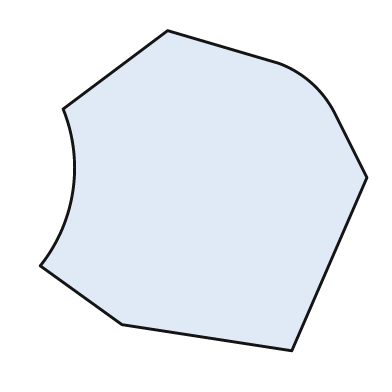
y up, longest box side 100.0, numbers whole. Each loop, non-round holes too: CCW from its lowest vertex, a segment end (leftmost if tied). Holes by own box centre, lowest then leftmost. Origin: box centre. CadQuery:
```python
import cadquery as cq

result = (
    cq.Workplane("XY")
    .moveTo(27.0, -49.0)
    .lineTo(50.0, 4.0)
    .lineTo(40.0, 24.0)
    .threePointArc((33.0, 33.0), (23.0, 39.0))
    .lineTo(-11.0, 49.0)
    .lineTo(-43.0, 25.0)
    .threePointArc((-40.0, 0.0), (-50.0, -23.0))
    .lineTo(-25.0, -41.0)
    .close()
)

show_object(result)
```